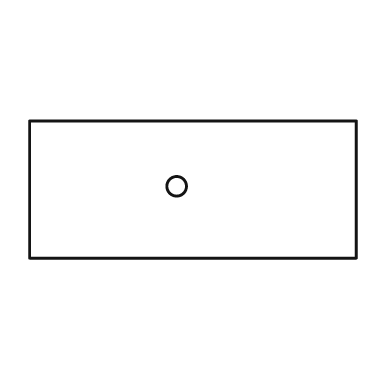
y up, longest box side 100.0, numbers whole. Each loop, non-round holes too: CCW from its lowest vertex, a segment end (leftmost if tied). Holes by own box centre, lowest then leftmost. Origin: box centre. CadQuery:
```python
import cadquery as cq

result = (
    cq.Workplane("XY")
    .moveTo(-50.0, -21.0)
    .lineTo(50.0, -21.0)
    .lineTo(50.0, 21.0)
    .lineTo(-50.0, 21.0)
    .close()
    .moveTo(-5.0, 1.0)
    .circle(3.0)
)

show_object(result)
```